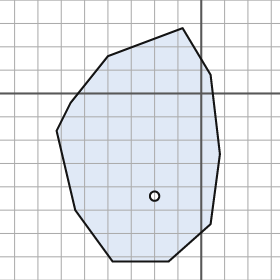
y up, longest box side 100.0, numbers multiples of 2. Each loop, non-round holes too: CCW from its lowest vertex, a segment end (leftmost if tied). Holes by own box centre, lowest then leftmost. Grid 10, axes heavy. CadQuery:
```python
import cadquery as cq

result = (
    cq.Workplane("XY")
    .moveTo(-38.0, -72.0)
    .lineTo(-14.0, -72.0)
    .lineTo(4.0, -56.0)
    .lineTo(8.0, -26.0)
    .lineTo(4.0, 8.0)
    .lineTo(-8.0, 28.0)
    .lineTo(-40.0, 16.0)
    .lineTo(-56.0, -4.0)
    .lineTo(-62.0, -16.0)
    .lineTo(-54.0, -50.0)
    .close()
    .moveTo(-20.0, -44.0)
    .circle(2.0)
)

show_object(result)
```